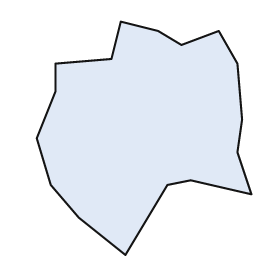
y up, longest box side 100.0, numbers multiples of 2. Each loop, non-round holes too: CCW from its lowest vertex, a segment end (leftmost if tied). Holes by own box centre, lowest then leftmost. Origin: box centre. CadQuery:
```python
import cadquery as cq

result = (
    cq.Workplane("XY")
    .moveTo(-8.0, -50.0)
    .lineTo(10.0, -20.0)
    .lineTo(20.0, -18.0)
    .lineTo(46.0, -24.0)
    .lineTo(40.0, -6.0)
    .lineTo(42.0, 8.0)
    .lineTo(40.0, 32.0)
    .lineTo(32.0, 46.0)
    .lineTo(16.0, 40.0)
    .lineTo(6.0, 46.0)
    .lineTo(-10.0, 50.0)
    .lineTo(-14.0, 34.0)
    .lineTo(-38.0, 32.0)
    .lineTo(-38.0, 20.0)
    .lineTo(-46.0, 0.0)
    .lineTo(-40.0, -20.0)
    .lineTo(-28.0, -34.0)
    .close()
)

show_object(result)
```